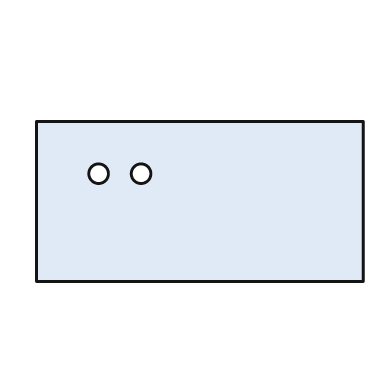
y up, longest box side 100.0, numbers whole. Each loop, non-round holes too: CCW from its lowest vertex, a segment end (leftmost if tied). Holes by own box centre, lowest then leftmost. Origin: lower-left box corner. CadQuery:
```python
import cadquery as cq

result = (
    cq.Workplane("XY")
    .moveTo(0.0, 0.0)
    .lineTo(100.0, 0.0)
    .lineTo(100.0, 49.0)
    .lineTo(0.0, 49.0)
    .close()
    .moveTo(19.0, 33.0)
    .circle(3.0)
    .moveTo(32.0, 33.0)
    .circle(3.0)
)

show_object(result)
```